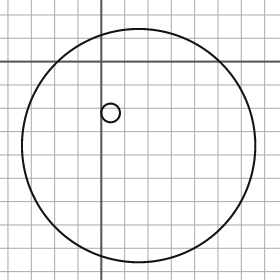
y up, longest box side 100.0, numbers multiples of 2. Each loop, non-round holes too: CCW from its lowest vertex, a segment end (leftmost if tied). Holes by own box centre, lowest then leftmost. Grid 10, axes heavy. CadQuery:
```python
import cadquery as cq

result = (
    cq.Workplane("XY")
    .moveTo(16.0, -36.0)
    .circle(50.0)
    .moveTo(4.0, -22.0)
    .circle(4.0)
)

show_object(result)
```